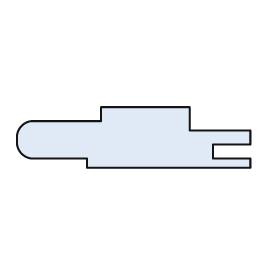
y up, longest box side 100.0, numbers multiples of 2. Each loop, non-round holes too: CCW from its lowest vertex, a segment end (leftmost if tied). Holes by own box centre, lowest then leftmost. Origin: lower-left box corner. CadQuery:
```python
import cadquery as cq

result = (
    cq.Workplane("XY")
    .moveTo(30.0, 0.0)
    .lineTo(100.0, 0.0)
    .lineTo(100.0, 4.0)
    .lineTo(84.0, 4.0)
    .lineTo(84.0, 10.0)
    .lineTo(100.0, 10.0)
    .lineTo(100.0, 16.0)
    .lineTo(74.0, 16.0)
    .lineTo(74.0, 26.0)
    .lineTo(36.0, 26.0)
    .lineTo(36.0, 20.0)
    .lineTo(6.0, 20.0)
    .threePointArc((2.0, 18.0), (0.0, 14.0))
    .lineTo(0.0, 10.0)
    .threePointArc((2.0, 6.0), (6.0, 4.0))
    .lineTo(30.0, 4.0)
    .close()
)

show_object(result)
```